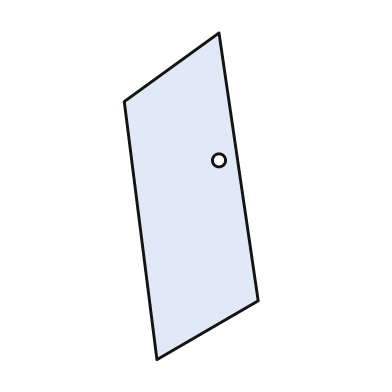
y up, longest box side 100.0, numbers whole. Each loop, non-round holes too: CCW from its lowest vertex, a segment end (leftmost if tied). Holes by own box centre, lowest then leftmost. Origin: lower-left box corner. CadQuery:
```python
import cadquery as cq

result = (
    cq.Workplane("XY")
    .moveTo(10.0, 0.0)
    .lineTo(41.0, 18.0)
    .lineTo(29.0, 100.0)
    .lineTo(0.0, 79.0)
    .close()
    .moveTo(29.0, 61.0)
    .circle(2.0)
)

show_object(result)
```